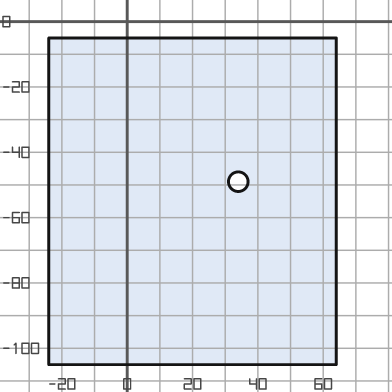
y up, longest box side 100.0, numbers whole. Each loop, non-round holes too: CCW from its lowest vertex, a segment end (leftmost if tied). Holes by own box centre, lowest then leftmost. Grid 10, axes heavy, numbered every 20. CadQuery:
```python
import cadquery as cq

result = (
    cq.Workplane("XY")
    .moveTo(-24.0, -105.0)
    .lineTo(64.0, -105.0)
    .lineTo(64.0, -5.0)
    .lineTo(-24.0, -5.0)
    .close()
    .moveTo(34.0, -49.0)
    .circle(3.0)
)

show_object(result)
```